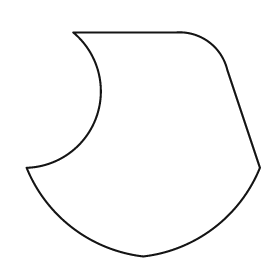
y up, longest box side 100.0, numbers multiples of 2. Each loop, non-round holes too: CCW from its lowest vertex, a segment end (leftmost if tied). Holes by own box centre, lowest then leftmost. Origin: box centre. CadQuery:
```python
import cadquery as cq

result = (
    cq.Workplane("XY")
    .moveTo(0.0, -48.0)
    .threePointArc((30.0, -36.0), (50.0, -10.0))
    .lineTo(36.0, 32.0)
    .threePointArc((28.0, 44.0), (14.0, 48.0))
    .lineTo(-30.0, 48.0)
    .threePointArc((-20.0, 12.0), (-50.0, -10.0))
    .threePointArc((-30.0, -36.0), (0.0, -48.0))
    .close()
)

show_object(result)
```